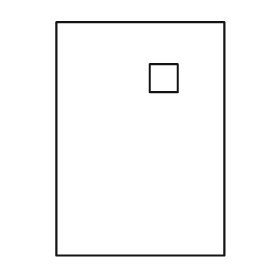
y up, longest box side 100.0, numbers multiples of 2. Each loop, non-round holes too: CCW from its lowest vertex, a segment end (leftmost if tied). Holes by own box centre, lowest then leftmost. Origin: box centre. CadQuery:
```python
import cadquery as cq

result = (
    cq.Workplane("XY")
    .moveTo(-36.0, -50.0)
    .lineTo(36.0, -50.0)
    .lineTo(36.0, 50.0)
    .lineTo(-36.0, 50.0)
    .close()
    .moveTo(4.0, 20.0)
    .lineTo(16.0, 20.0)
    .lineTo(16.0, 32.0)
    .lineTo(4.0, 32.0)
    .close()
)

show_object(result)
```